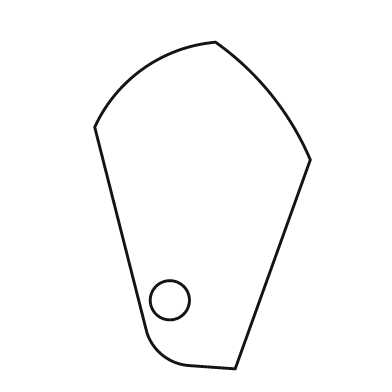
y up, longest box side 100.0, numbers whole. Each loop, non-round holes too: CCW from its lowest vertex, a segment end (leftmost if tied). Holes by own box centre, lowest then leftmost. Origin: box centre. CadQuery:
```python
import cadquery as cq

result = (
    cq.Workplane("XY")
    .moveTo(10.0, -50.0)
    .lineTo(33.0, 14.0)
    .threePointArc((21.0, 34.0), (4.0, 50.0))
    .threePointArc((-18.0, 42.0), (-33.0, 24.0))
    .lineTo(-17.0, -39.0)
    .threePointArc((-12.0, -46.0), (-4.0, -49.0))
    .close()
    .moveTo(-10.0, -29.0)
    .circle(6.0)
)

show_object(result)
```